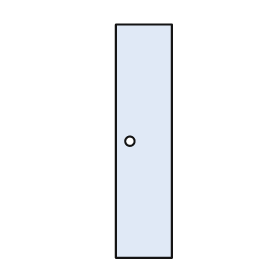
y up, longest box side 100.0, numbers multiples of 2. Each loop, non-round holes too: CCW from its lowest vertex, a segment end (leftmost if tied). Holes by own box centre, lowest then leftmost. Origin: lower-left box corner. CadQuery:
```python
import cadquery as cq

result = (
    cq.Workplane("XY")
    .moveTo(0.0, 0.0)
    .lineTo(24.0, 0.0)
    .lineTo(24.0, 100.0)
    .lineTo(0.0, 100.0)
    .close()
    .moveTo(6.0, 50.0)
    .circle(2.0)
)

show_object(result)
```